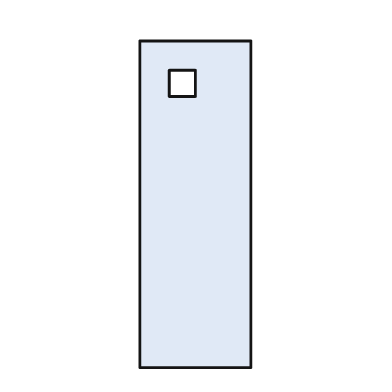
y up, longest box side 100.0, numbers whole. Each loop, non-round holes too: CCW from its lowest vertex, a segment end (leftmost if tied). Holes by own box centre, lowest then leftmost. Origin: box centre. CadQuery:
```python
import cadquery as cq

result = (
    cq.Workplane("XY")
    .moveTo(-17.0, -50.0)
    .lineTo(17.0, -50.0)
    .lineTo(17.0, 50.0)
    .lineTo(-17.0, 50.0)
    .close()
    .moveTo(-8.0, 33.0)
    .lineTo(0.0, 33.0)
    .lineTo(0.0, 41.0)
    .lineTo(-8.0, 41.0)
    .close()
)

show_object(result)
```